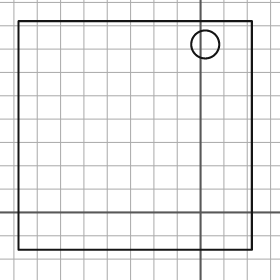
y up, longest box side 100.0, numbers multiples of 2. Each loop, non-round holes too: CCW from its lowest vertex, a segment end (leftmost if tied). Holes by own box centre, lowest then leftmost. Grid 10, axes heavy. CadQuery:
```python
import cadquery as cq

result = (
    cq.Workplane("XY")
    .moveTo(-78.0, -16.0)
    .lineTo(22.0, -16.0)
    .lineTo(22.0, 82.0)
    .lineTo(-78.0, 82.0)
    .close()
    .moveTo(2.0, 72.0)
    .circle(6.0)
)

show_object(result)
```